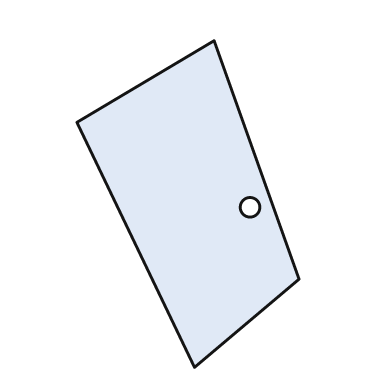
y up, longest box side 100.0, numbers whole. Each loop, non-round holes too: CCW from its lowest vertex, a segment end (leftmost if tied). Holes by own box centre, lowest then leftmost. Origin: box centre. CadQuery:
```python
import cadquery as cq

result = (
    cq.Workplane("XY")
    .moveTo(2.0, -50.0)
    .lineTo(34.0, -23.0)
    .lineTo(8.0, 50.0)
    .lineTo(-34.0, 25.0)
    .close()
    .moveTo(19.0, -1.0)
    .circle(3.0)
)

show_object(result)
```